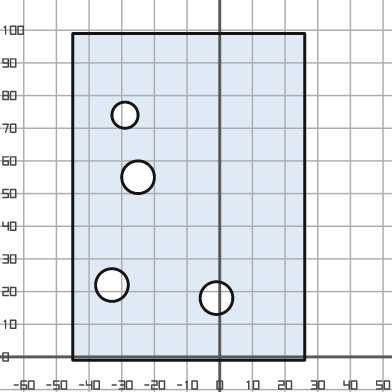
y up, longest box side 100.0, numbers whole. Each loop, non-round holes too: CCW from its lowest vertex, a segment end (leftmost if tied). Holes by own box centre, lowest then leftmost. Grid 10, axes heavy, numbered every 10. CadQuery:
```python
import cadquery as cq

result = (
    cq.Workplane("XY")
    .moveTo(-45.0, -1.0)
    .lineTo(26.0, -1.0)
    .lineTo(26.0, 99.0)
    .lineTo(-45.0, 99.0)
    .close()
    .moveTo(-1.0, 18.0)
    .circle(5.0)
    .moveTo(-33.0, 22.0)
    .circle(5.0)
    .moveTo(-25.0, 55.0)
    .circle(5.0)
    .moveTo(-29.0, 74.0)
    .circle(4.0)
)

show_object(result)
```